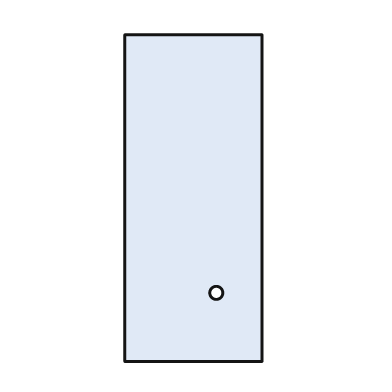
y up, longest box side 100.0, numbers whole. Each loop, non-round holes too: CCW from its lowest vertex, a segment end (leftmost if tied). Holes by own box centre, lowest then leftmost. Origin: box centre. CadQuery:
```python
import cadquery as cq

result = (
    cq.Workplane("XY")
    .moveTo(-21.0, -50.0)
    .lineTo(21.0, -50.0)
    .lineTo(21.0, 50.0)
    .lineTo(-21.0, 50.0)
    .close()
    .moveTo(7.0, -29.0)
    .circle(2.0)
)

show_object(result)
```